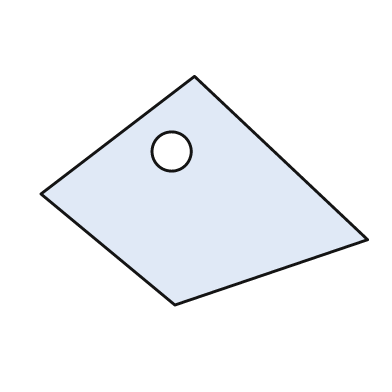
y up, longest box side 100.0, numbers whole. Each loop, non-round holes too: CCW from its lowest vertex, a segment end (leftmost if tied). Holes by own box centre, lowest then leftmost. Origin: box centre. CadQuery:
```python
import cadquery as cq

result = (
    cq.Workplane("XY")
    .moveTo(-9.0, -35.0)
    .lineTo(50.0, -15.0)
    .lineTo(-3.0, 35.0)
    .lineTo(-50.0, -1.0)
    .close()
    .moveTo(-10.0, 12.0)
    .circle(6.0)
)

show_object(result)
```